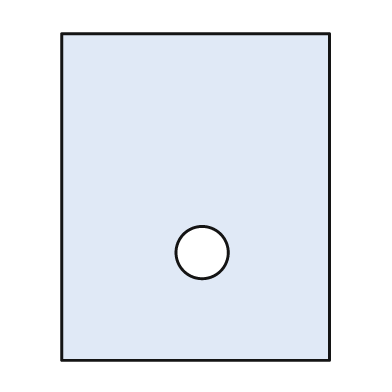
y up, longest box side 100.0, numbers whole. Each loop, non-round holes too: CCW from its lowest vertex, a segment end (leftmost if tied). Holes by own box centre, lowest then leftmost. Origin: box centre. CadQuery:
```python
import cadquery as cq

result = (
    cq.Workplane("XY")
    .moveTo(-41.0, -50.0)
    .lineTo(41.0, -50.0)
    .lineTo(41.0, 50.0)
    .lineTo(-41.0, 50.0)
    .close()
    .moveTo(2.0, -17.0)
    .circle(8.0)
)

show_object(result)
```